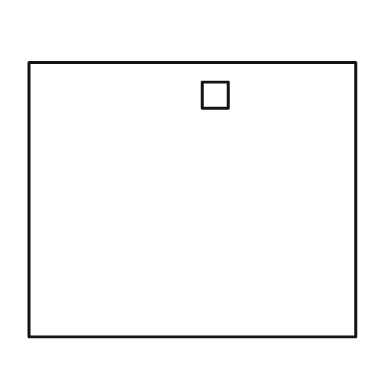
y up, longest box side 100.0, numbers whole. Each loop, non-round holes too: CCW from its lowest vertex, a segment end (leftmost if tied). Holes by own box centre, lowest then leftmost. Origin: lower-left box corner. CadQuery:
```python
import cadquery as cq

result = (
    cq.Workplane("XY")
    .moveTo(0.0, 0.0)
    .lineTo(100.0, 0.0)
    .lineTo(100.0, 84.0)
    .lineTo(0.0, 84.0)
    .close()
    .moveTo(53.0, 70.0)
    .lineTo(61.0, 70.0)
    .lineTo(61.0, 78.0)
    .lineTo(53.0, 78.0)
    .close()
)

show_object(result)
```